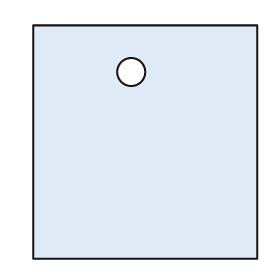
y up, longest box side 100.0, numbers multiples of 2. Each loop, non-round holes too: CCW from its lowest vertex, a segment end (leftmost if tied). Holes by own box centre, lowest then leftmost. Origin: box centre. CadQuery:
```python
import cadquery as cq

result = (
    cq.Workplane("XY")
    .moveTo(-48.0, -50.0)
    .lineTo(48.0, -50.0)
    .lineTo(48.0, 50.0)
    .lineTo(-48.0, 50.0)
    .close()
    .moveTo(-6.0, 30.0)
    .circle(6.0)
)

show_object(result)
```